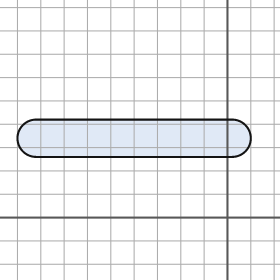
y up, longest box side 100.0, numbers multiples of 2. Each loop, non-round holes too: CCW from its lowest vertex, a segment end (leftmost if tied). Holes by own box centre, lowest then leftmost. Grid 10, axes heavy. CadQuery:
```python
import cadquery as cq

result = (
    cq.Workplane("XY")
    .moveTo(-82.0, 26.0)
    .lineTo(2.0, 26.0)
    .threePointArc((10.0, 34.0), (2.0, 42.0))
    .lineTo(-82.0, 42.0)
    .threePointArc((-90.0, 34.0), (-82.0, 26.0))
    .close()
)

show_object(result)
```